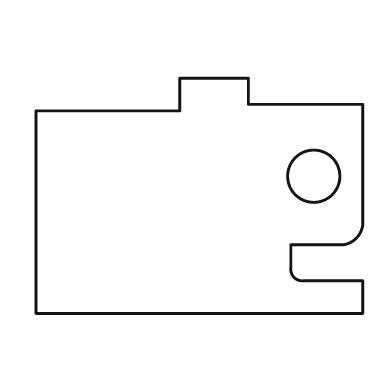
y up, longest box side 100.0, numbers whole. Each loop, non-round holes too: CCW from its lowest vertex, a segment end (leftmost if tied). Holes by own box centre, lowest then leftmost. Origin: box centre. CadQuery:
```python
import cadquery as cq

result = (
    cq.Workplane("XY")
    .moveTo(-50.0, -36.0)
    .lineTo(50.0, -36.0)
    .lineTo(50.0, -26.0)
    .lineTo(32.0, -26.0)
    .threePointArc((29.0, -25.0), (28.0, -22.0))
    .lineTo(28.0, -15.0)
    .lineTo(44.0, -15.0)
    .threePointArc((48.0, -13.0), (50.0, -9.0))
    .lineTo(50.0, 28.0)
    .lineTo(15.0, 28.0)
    .lineTo(15.0, 36.0)
    .lineTo(-6.0, 36.0)
    .lineTo(-6.0, 26.0)
    .lineTo(-50.0, 26.0)
    .close()
    .moveTo(35.0, 6.0)
    .circle(8.0)
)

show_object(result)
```